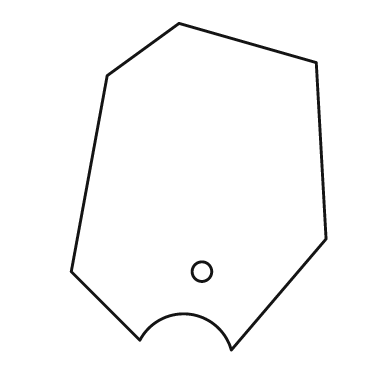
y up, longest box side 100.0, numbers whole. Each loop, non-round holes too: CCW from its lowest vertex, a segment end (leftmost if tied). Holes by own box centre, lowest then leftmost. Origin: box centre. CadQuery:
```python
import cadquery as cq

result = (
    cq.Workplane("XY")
    .moveTo(10.0, -50.0)
    .lineTo(39.0, -16.0)
    .lineTo(36.0, 38.0)
    .lineTo(-6.0, 50.0)
    .lineTo(-28.0, 34.0)
    .lineTo(-39.0, -26.0)
    .lineTo(-18.0, -47.0)
    .threePointArc((-3.0, -39.0), (10.0, -50.0))
    .close()
    .moveTo(1.0, -26.0)
    .circle(3.0)
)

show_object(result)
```